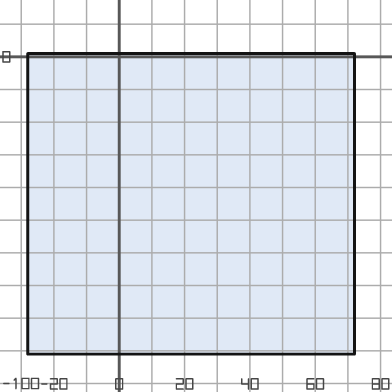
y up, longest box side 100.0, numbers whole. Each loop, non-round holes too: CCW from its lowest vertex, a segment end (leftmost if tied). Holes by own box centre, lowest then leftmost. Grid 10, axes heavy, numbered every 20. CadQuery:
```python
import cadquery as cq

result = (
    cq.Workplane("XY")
    .moveTo(-28.0, -91.0)
    .lineTo(72.0, -91.0)
    .lineTo(72.0, 1.0)
    .lineTo(-28.0, 1.0)
    .close()
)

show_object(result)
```